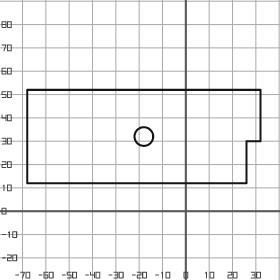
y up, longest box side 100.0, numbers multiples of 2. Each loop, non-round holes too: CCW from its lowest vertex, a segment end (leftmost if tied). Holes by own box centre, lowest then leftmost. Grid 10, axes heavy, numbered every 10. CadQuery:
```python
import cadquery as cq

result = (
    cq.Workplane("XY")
    .moveTo(-68.0, 12.0)
    .lineTo(26.0, 12.0)
    .lineTo(26.0, 30.0)
    .lineTo(32.0, 30.0)
    .lineTo(32.0, 52.0)
    .lineTo(-68.0, 52.0)
    .close()
    .moveTo(-18.0, 32.0)
    .circle(4.0)
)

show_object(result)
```